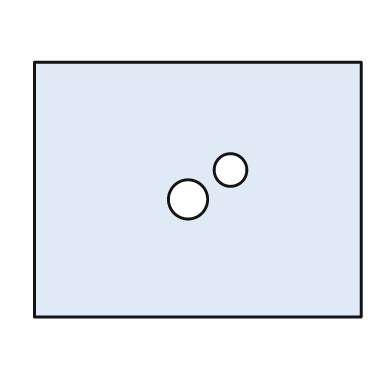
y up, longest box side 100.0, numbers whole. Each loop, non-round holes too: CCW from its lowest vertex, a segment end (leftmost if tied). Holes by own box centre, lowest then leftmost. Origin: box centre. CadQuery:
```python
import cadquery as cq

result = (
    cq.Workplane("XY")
    .moveTo(-50.0, -39.0)
    .lineTo(50.0, -39.0)
    .lineTo(50.0, 39.0)
    .lineTo(-50.0, 39.0)
    .close()
    .moveTo(-3.0, -3.0)
    .circle(6.0)
    .moveTo(10.0, 6.0)
    .circle(5.0)
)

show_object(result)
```